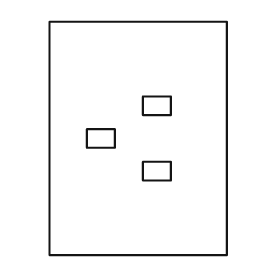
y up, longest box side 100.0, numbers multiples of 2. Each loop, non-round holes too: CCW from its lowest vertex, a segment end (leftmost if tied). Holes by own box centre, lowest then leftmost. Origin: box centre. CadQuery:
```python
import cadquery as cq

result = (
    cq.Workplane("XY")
    .moveTo(-38.0, -50.0)
    .lineTo(38.0, -50.0)
    .lineTo(38.0, 50.0)
    .lineTo(-38.0, 50.0)
    .close()
    .moveTo(2.0, -18.0)
    .lineTo(14.0, -18.0)
    .lineTo(14.0, -10.0)
    .lineTo(2.0, -10.0)
    .close()
    .moveTo(-22.0, -4.0)
    .lineTo(-10.0, -4.0)
    .lineTo(-10.0, 4.0)
    .lineTo(-22.0, 4.0)
    .close()
    .moveTo(2.0, 10.0)
    .lineTo(14.0, 10.0)
    .lineTo(14.0, 18.0)
    .lineTo(2.0, 18.0)
    .close()
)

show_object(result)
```